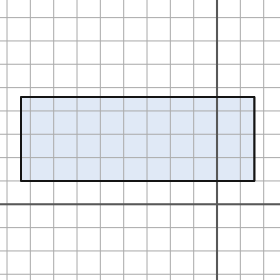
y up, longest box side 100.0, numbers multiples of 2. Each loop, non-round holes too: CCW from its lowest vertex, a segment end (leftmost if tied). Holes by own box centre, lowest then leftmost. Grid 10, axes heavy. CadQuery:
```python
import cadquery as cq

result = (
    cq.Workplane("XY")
    .moveTo(-84.0, 10.0)
    .lineTo(16.0, 10.0)
    .lineTo(16.0, 46.0)
    .lineTo(-84.0, 46.0)
    .close()
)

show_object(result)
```